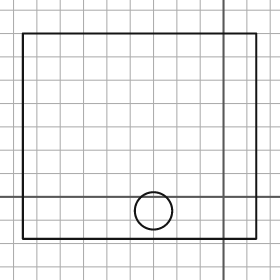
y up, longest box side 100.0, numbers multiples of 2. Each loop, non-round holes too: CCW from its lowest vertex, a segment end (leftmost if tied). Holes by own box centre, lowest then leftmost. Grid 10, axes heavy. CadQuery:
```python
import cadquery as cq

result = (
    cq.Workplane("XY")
    .moveTo(-86.0, -18.0)
    .lineTo(14.0, -18.0)
    .lineTo(14.0, 70.0)
    .lineTo(-86.0, 70.0)
    .close()
    .moveTo(-30.0, -6.0)
    .circle(8.0)
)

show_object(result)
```